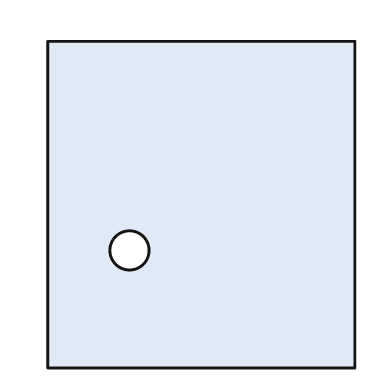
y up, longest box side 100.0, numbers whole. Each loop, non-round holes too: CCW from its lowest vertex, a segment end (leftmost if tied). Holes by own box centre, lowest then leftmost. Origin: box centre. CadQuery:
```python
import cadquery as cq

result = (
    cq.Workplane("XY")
    .moveTo(-47.0, -50.0)
    .lineTo(47.0, -50.0)
    .lineTo(47.0, 50.0)
    .lineTo(-47.0, 50.0)
    .close()
    .moveTo(-22.0, -14.0)
    .circle(6.0)
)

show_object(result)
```